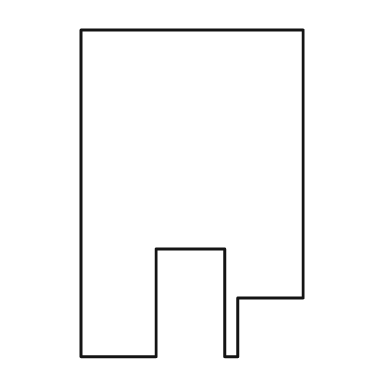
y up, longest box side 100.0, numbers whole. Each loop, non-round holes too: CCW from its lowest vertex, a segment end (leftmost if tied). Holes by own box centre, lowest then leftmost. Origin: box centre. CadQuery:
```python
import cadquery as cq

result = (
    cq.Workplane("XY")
    .moveTo(-34.0, -50.0)
    .lineTo(-11.0, -50.0)
    .lineTo(-11.0, -17.0)
    .lineTo(10.0, -17.0)
    .lineTo(10.0, -50.0)
    .lineTo(14.0, -50.0)
    .lineTo(14.0, -32.0)
    .lineTo(34.0, -32.0)
    .lineTo(34.0, 50.0)
    .lineTo(-34.0, 50.0)
    .close()
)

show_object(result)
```